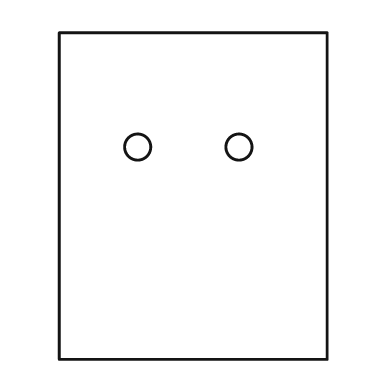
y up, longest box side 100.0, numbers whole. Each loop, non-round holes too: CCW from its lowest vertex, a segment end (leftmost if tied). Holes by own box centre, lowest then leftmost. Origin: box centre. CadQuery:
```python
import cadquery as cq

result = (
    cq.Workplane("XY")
    .moveTo(-41.0, -50.0)
    .lineTo(41.0, -50.0)
    .lineTo(41.0, 50.0)
    .lineTo(-41.0, 50.0)
    .close()
    .moveTo(-17.0, 15.0)
    .circle(4.0)
    .moveTo(14.0, 15.0)
    .circle(4.0)
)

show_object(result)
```